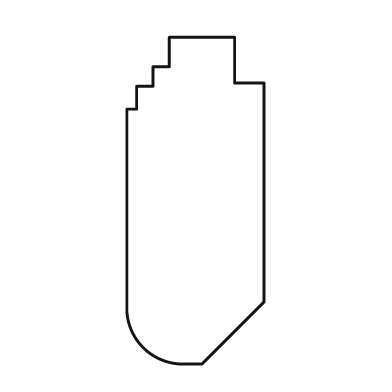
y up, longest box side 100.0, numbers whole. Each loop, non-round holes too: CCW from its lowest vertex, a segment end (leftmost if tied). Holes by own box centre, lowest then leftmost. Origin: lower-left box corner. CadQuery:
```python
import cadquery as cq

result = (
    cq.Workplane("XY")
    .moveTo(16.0, 0.0)
    .lineTo(23.0, 0.0)
    .lineTo(42.0, 19.0)
    .lineTo(42.0, 86.0)
    .lineTo(33.0, 86.0)
    .lineTo(33.0, 100.0)
    .lineTo(13.0, 100.0)
    .lineTo(13.0, 91.0)
    .lineTo(8.0, 91.0)
    .lineTo(8.0, 85.0)
    .lineTo(3.0, 85.0)
    .lineTo(3.0, 78.0)
    .lineTo(0.0, 78.0)
    .lineTo(0.0, 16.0)
    .threePointArc((5.0, 5.0), (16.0, 0.0))
    .close()
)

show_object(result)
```